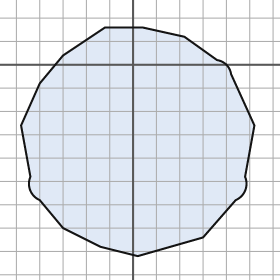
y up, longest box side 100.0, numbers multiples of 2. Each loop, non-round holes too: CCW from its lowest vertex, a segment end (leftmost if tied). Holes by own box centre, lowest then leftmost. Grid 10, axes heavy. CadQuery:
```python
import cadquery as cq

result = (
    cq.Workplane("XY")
    .moveTo(2.0, -82.0)
    .lineTo(30.0, -74.0)
    .lineTo(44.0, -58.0)
    .threePointArc((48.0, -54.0), (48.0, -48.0))
    .lineTo(52.0, -26.0)
    .lineTo(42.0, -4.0)
    .threePointArc((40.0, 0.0), (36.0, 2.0))
    .lineTo(22.0, 12.0)
    .lineTo(4.0, 16.0)
    .lineTo(-12.0, 16.0)
    .lineTo(-30.0, 4.0)
    .lineTo(-40.0, -8.0)
    .lineTo(-48.0, -26.0)
    .lineTo(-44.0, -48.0)
    .threePointArc((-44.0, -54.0), (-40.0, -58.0))
    .lineTo(-30.0, -70.0)
    .lineTo(-14.0, -78.0)
    .close()
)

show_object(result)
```